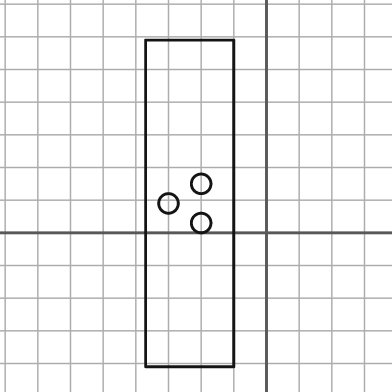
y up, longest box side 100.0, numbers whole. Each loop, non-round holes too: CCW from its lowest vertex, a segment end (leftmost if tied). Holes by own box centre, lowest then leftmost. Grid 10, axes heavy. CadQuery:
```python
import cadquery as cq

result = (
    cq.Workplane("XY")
    .moveTo(-37.0, -41.0)
    .lineTo(-10.0, -41.0)
    .lineTo(-10.0, 59.0)
    .lineTo(-37.0, 59.0)
    .close()
    .moveTo(-20.0, 3.0)
    .circle(3.0)
    .moveTo(-30.0, 9.0)
    .circle(3.0)
    .moveTo(-20.0, 15.0)
    .circle(3.0)
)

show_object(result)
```